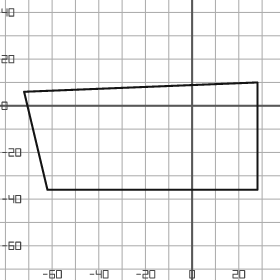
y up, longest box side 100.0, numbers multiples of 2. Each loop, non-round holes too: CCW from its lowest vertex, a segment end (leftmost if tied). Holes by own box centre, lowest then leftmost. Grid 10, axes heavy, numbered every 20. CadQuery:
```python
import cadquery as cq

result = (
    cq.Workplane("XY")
    .moveTo(-62.0, -36.0)
    .lineTo(28.0, -36.0)
    .lineTo(28.0, 10.0)
    .lineTo(-72.0, 6.0)
    .close()
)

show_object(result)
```